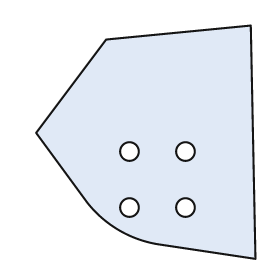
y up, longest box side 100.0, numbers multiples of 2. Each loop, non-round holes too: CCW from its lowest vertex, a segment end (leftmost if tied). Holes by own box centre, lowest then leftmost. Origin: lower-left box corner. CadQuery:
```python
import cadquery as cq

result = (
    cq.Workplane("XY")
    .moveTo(94.0, 0.0)
    .lineTo(92.0, 100.0)
    .lineTo(30.0, 94.0)
    .lineTo(0.0, 54.0)
    .lineTo(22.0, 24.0)
    .threePointArc((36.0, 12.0), (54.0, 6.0))
    .close()
    .moveTo(40.0, 22.0)
    .circle(4.0)
    .moveTo(64.0, 22.0)
    .circle(4.0)
    .moveTo(40.0, 46.0)
    .circle(4.0)
    .moveTo(64.0, 46.0)
    .circle(4.0)
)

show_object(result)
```